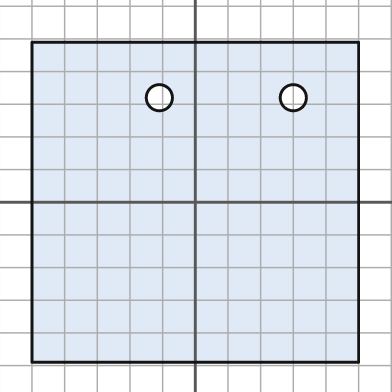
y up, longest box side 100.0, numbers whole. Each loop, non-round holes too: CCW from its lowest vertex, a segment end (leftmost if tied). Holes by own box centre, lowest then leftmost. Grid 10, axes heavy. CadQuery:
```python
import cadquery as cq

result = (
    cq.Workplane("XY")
    .moveTo(-50.0, -49.0)
    .lineTo(50.0, -49.0)
    .lineTo(50.0, 49.0)
    .lineTo(-50.0, 49.0)
    .close()
    .moveTo(-11.0, 32.0)
    .circle(4.0)
    .moveTo(30.0, 32.0)
    .circle(4.0)
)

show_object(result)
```